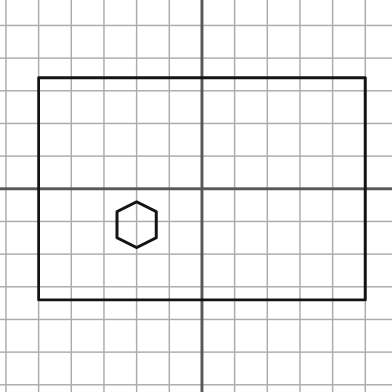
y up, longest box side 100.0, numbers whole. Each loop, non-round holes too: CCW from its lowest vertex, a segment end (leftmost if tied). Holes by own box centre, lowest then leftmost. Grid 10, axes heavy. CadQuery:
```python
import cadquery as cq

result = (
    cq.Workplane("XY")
    .moveTo(-50.0, -34.0)
    .lineTo(50.0, -34.0)
    .lineTo(50.0, 34.0)
    .lineTo(-50.0, 34.0)
    .close()
    .moveTo(-20.0, -18.0)
    .lineTo(-14.0, -15.0)
    .lineTo(-14.0, -7.0)
    .lineTo(-20.0, -4.0)
    .lineTo(-26.0, -7.0)
    .lineTo(-26.0, -15.0)
    .close()
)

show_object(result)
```